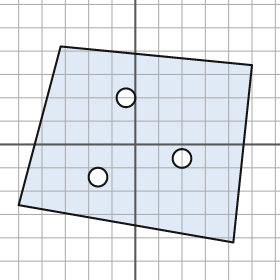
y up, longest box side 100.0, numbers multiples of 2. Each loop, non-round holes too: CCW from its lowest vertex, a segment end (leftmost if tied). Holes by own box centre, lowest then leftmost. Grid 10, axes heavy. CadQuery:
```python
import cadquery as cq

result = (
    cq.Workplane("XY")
    .moveTo(42.0, -42.0)
    .lineTo(50.0, 34.0)
    .lineTo(-32.0, 42.0)
    .lineTo(-50.0, -26.0)
    .close()
    .moveTo(-16.0, -14.0)
    .circle(4.0)
    .moveTo(20.0, -6.0)
    .circle(4.0)
    .moveTo(-4.0, 20.0)
    .circle(4.0)
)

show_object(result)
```